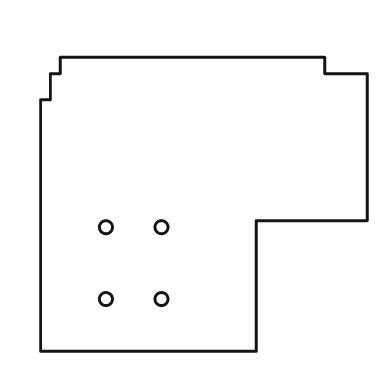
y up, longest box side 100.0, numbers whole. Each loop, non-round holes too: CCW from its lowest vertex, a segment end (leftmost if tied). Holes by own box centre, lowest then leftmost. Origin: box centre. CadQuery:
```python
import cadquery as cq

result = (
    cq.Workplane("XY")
    .moveTo(-50.0, -45.0)
    .lineTo(16.0, -45.0)
    .lineTo(16.0, -5.0)
    .lineTo(50.0, -5.0)
    .lineTo(50.0, 40.0)
    .lineTo(37.0, 40.0)
    .lineTo(37.0, 45.0)
    .lineTo(-44.0, 45.0)
    .lineTo(-44.0, 40.0)
    .lineTo(-47.0, 40.0)
    .lineTo(-47.0, 32.0)
    .lineTo(-50.0, 32.0)
    .close()
    .moveTo(-30.0, -29.0)
    .circle(2.0)
    .moveTo(-13.0, -29.0)
    .circle(2.0)
    .moveTo(-30.0, -7.0)
    .circle(2.0)
    .moveTo(-13.0, -7.0)
    .circle(2.0)
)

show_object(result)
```